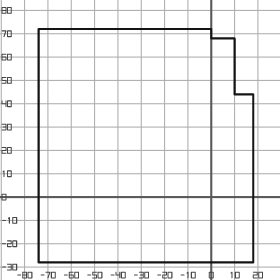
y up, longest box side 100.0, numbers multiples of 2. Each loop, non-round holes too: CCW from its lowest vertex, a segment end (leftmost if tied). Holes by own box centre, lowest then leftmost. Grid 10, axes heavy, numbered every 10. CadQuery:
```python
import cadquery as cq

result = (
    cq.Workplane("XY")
    .moveTo(-74.0, -28.0)
    .lineTo(18.0, -28.0)
    .lineTo(18.0, 44.0)
    .lineTo(10.0, 44.0)
    .lineTo(10.0, 68.0)
    .lineTo(0.0, 68.0)
    .lineTo(0.0, 72.0)
    .lineTo(-74.0, 72.0)
    .close()
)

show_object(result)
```